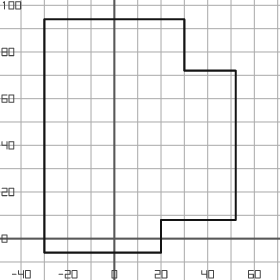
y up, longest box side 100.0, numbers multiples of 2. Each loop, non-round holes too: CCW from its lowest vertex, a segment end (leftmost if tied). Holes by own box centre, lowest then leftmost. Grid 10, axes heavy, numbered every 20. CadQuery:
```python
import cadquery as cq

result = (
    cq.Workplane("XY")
    .moveTo(-30.0, -6.0)
    .lineTo(20.0, -6.0)
    .lineTo(20.0, 8.0)
    .lineTo(52.0, 8.0)
    .lineTo(52.0, 72.0)
    .lineTo(30.0, 72.0)
    .lineTo(30.0, 94.0)
    .lineTo(-30.0, 94.0)
    .close()
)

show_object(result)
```